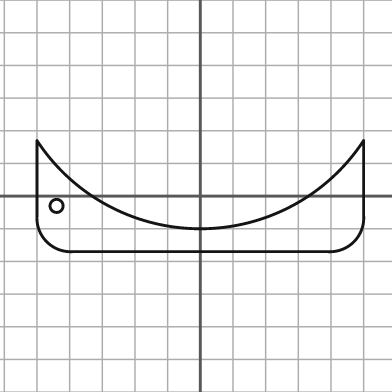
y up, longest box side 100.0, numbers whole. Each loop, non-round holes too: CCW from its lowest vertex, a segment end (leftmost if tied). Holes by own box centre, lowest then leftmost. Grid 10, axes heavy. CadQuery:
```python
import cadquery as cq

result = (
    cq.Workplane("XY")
    .moveTo(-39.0, -17.0)
    .lineTo(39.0, -17.0)
    .threePointArc((47.0, -14.0), (50.0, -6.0))
    .lineTo(50.0, 17.0)
    .threePointArc((0.0, -10.0), (-50.0, 17.0))
    .lineTo(-50.0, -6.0)
    .threePointArc((-47.0, -14.0), (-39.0, -17.0))
    .close()
    .moveTo(-44.0, -3.0)
    .circle(2.0)
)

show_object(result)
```